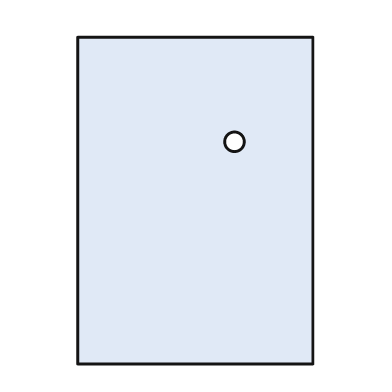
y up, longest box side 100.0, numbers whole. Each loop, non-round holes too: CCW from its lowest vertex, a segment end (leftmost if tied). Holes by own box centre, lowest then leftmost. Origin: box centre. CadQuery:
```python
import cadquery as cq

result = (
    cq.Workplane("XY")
    .moveTo(-36.0, -50.0)
    .lineTo(36.0, -50.0)
    .lineTo(36.0, 50.0)
    .lineTo(-36.0, 50.0)
    .close()
    .moveTo(12.0, 18.0)
    .circle(3.0)
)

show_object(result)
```